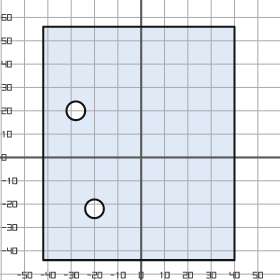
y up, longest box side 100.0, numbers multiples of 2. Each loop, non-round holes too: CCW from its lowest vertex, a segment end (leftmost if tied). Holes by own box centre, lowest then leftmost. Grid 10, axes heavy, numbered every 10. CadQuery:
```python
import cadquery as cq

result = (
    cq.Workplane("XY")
    .moveTo(-42.0, -44.0)
    .lineTo(40.0, -44.0)
    .lineTo(40.0, 56.0)
    .lineTo(-42.0, 56.0)
    .close()
    .moveTo(-20.0, -22.0)
    .circle(4.0)
    .moveTo(-28.0, 20.0)
    .circle(4.0)
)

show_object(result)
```